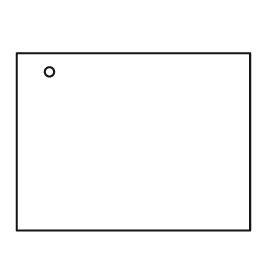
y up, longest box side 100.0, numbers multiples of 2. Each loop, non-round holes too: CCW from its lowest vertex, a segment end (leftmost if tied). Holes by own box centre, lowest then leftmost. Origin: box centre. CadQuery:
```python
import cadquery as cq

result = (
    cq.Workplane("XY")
    .moveTo(-50.0, -38.0)
    .lineTo(50.0, -38.0)
    .lineTo(50.0, 38.0)
    .lineTo(-50.0, 38.0)
    .close()
    .moveTo(-36.0, 30.0)
    .circle(2.0)
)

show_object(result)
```